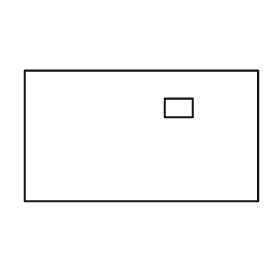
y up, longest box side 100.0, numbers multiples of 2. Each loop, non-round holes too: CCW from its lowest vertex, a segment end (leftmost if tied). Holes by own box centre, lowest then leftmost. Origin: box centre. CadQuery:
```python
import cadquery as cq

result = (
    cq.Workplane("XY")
    .moveTo(-50.0, -28.0)
    .lineTo(50.0, -28.0)
    .lineTo(50.0, 28.0)
    .lineTo(-50.0, 28.0)
    .close()
    .moveTo(10.0, 8.0)
    .lineTo(22.0, 8.0)
    .lineTo(22.0, 16.0)
    .lineTo(10.0, 16.0)
    .close()
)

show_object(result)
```